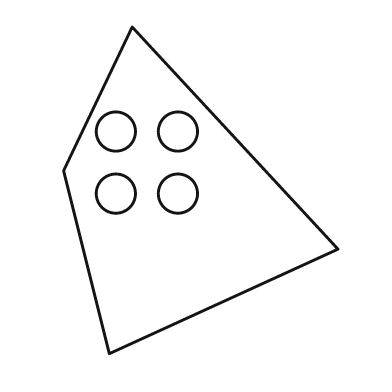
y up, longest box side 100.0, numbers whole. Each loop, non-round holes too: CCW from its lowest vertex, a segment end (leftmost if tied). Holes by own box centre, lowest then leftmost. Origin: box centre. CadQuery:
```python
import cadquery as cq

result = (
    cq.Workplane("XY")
    .moveTo(-28.0, -50.0)
    .lineTo(42.0, -18.0)
    .lineTo(-21.0, 50.0)
    .lineTo(-42.0, 6.0)
    .close()
    .moveTo(-26.0, -1.0)
    .circle(6.0)
    .moveTo(-7.0, -1.0)
    .circle(6.0)
    .moveTo(-26.0, 18.0)
    .circle(6.0)
    .moveTo(-7.0, 18.0)
    .circle(6.0)
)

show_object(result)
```